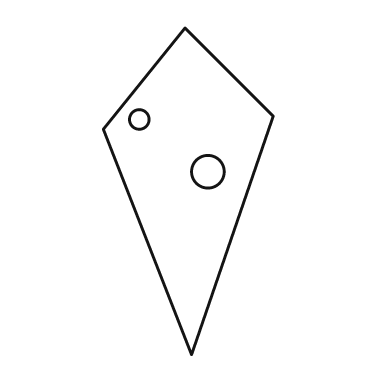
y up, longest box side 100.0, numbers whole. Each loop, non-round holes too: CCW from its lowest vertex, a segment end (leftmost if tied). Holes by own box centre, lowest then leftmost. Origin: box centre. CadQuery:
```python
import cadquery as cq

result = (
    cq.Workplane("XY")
    .moveTo(1.0, -50.0)
    .lineTo(26.0, 23.0)
    .lineTo(-1.0, 50.0)
    .lineTo(-26.0, 19.0)
    .close()
    .moveTo(6.0, 6.0)
    .circle(5.0)
    .moveTo(-15.0, 22.0)
    .circle(3.0)
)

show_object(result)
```